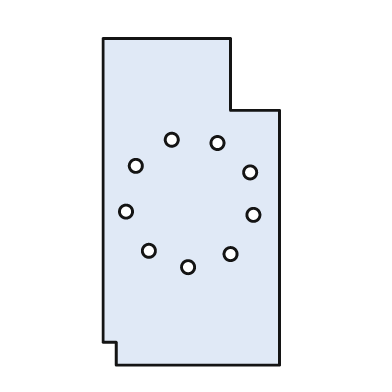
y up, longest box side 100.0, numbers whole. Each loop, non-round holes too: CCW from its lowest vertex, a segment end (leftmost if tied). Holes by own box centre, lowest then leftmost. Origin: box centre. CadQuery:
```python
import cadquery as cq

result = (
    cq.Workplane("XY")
    .moveTo(-23.0, -50.0)
    .lineTo(27.0, -50.0)
    .lineTo(27.0, 28.0)
    .lineTo(12.0, 28.0)
    .lineTo(12.0, 50.0)
    .lineTo(-27.0, 50.0)
    .lineTo(-27.0, -43.0)
    .lineTo(-23.0, -43.0)
    .close()
    .moveTo(-1.0, -20.0)
    .circle(2.0)
    .moveTo(12.0, -16.0)
    .circle(2.0)
    .moveTo(-13.0, -15.0)
    .circle(2.0)
    .moveTo(19.0, -4.0)
    .circle(2.0)
    .moveTo(-20.0, -3.0)
    .circle(2.0)
    .moveTo(18.0, 9.0)
    .circle(2.0)
    .moveTo(-17.0, 11.0)
    .circle(2.0)
    .moveTo(8.0, 18.0)
    .circle(2.0)
    .moveTo(-6.0, 19.0)
    .circle(2.0)
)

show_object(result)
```